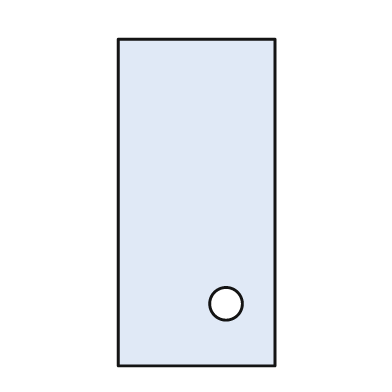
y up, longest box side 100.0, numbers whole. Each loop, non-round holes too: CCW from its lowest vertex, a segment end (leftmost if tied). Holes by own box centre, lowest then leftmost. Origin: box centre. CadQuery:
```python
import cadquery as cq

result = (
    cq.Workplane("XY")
    .moveTo(-24.0, -50.0)
    .lineTo(24.0, -50.0)
    .lineTo(24.0, 50.0)
    .lineTo(-24.0, 50.0)
    .close()
    .moveTo(9.0, -31.0)
    .circle(5.0)
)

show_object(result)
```